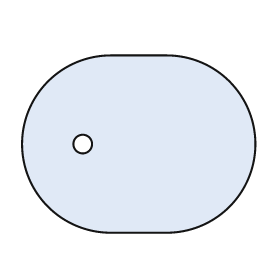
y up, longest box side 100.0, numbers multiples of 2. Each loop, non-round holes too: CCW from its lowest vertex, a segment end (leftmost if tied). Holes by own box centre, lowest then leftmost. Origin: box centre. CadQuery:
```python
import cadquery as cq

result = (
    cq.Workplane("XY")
    .moveTo(-12.0, -38.0)
    .lineTo(12.0, -38.0)
    .threePointArc((50.0, 0.0), (12.0, 38.0))
    .lineTo(-12.0, 38.0)
    .threePointArc((-50.0, 0.0), (-12.0, -38.0))
    .close()
    .moveTo(-24.0, 0.0)
    .circle(4.0)
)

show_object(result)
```